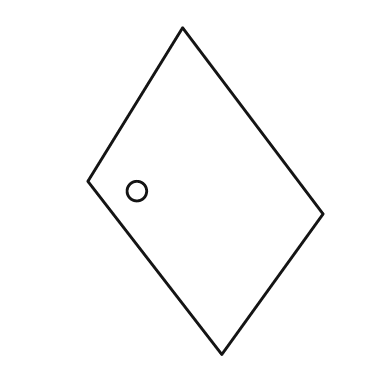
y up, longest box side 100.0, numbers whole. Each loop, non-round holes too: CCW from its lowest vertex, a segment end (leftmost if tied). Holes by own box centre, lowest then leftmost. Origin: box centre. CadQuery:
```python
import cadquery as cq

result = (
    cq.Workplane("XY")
    .moveTo(5.0, -50.0)
    .lineTo(36.0, -7.0)
    .lineTo(-7.0, 50.0)
    .lineTo(-36.0, 3.0)
    .close()
    .moveTo(-21.0, 0.0)
    .circle(3.0)
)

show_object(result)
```